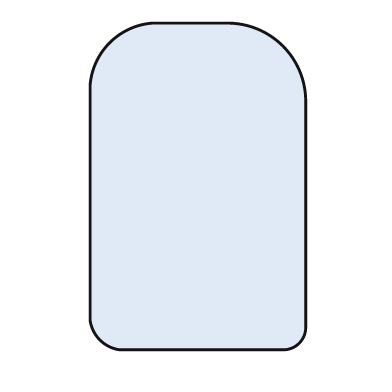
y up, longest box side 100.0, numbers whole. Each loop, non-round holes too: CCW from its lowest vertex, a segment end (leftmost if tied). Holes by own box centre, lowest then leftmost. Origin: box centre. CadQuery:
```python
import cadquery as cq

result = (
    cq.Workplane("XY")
    .moveTo(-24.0, -50.0)
    .lineTo(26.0, -50.0)
    .threePointArc((31.0, -48.0), (33.0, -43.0))
    .lineTo(33.0, 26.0)
    .threePointArc((26.0, 43.0), (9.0, 50.0))
    .lineTo(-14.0, 50.0)
    .threePointArc((-27.0, 44.0), (-33.0, 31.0))
    .lineTo(-33.0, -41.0)
    .threePointArc((-30.0, -47.0), (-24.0, -50.0))
    .close()
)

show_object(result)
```